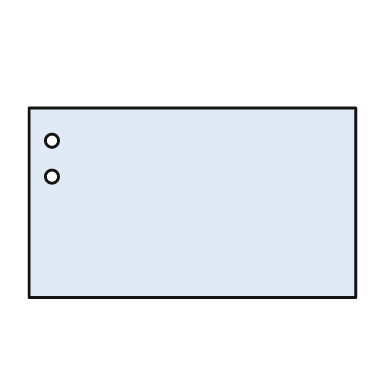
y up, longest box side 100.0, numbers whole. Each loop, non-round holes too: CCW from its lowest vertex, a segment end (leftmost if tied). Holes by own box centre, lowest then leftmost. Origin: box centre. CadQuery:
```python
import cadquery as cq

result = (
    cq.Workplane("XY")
    .moveTo(-50.0, -29.0)
    .lineTo(50.0, -29.0)
    .lineTo(50.0, 29.0)
    .lineTo(-50.0, 29.0)
    .close()
    .moveTo(-43.0, 8.0)
    .circle(2.0)
    .moveTo(-43.0, 19.0)
    .circle(2.0)
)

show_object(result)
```